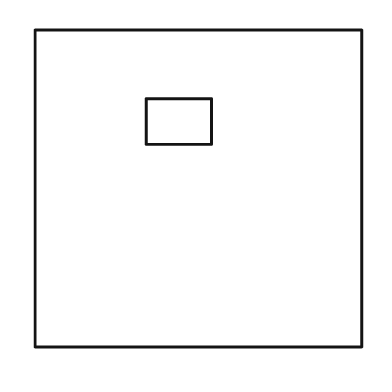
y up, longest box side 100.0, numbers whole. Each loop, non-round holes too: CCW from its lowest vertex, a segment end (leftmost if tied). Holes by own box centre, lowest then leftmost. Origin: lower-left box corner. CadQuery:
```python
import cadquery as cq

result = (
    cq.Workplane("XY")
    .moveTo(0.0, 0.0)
    .lineTo(100.0, 0.0)
    .lineTo(100.0, 97.0)
    .lineTo(0.0, 97.0)
    .close()
    .moveTo(34.0, 62.0)
    .lineTo(54.0, 62.0)
    .lineTo(54.0, 76.0)
    .lineTo(34.0, 76.0)
    .close()
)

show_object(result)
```